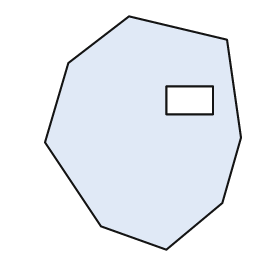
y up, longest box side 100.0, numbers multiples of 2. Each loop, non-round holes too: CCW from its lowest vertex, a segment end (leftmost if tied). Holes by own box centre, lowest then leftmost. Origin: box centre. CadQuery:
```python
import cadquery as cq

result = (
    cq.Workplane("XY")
    .moveTo(10.0, -50.0)
    .lineTo(34.0, -30.0)
    .lineTo(42.0, -2.0)
    .lineTo(36.0, 40.0)
    .lineTo(-6.0, 50.0)
    .lineTo(-32.0, 30.0)
    .lineTo(-42.0, -4.0)
    .lineTo(-18.0, -40.0)
    .close()
    .moveTo(10.0, 8.0)
    .lineTo(30.0, 8.0)
    .lineTo(30.0, 20.0)
    .lineTo(10.0, 20.0)
    .close()
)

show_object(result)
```